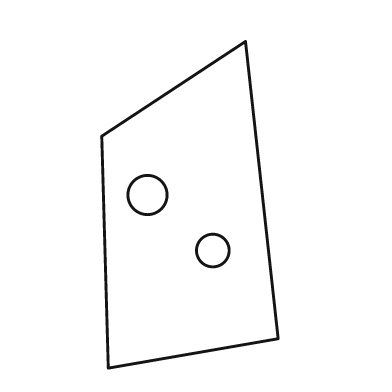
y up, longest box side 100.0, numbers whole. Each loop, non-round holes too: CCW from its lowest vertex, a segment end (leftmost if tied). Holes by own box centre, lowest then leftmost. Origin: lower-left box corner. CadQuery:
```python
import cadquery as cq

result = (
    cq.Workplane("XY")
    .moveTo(2.0, 0.0)
    .lineTo(54.0, 9.0)
    .lineTo(44.0, 100.0)
    .lineTo(0.0, 71.0)
    .close()
    .moveTo(34.0, 36.0)
    .circle(5.0)
    .moveTo(14.0, 53.0)
    .circle(6.0)
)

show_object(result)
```